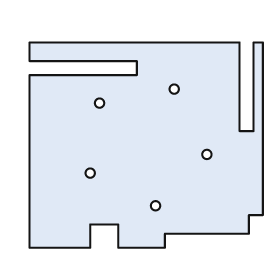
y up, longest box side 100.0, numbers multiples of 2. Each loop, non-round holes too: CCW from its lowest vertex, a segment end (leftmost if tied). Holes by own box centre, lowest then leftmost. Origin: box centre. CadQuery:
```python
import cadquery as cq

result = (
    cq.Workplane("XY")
    .moveTo(-50.0, -44.0)
    .lineTo(-24.0, -44.0)
    .lineTo(-24.0, -34.0)
    .lineTo(-12.0, -34.0)
    .lineTo(-12.0, -44.0)
    .lineTo(8.0, -44.0)
    .lineTo(8.0, -38.0)
    .lineTo(44.0, -38.0)
    .lineTo(44.0, -30.0)
    .lineTo(50.0, -30.0)
    .lineTo(50.0, 44.0)
    .lineTo(46.0, 44.0)
    .lineTo(46.0, 6.0)
    .lineTo(40.0, 6.0)
    .lineTo(40.0, 44.0)
    .lineTo(-50.0, 44.0)
    .lineTo(-50.0, 36.0)
    .lineTo(-4.0, 36.0)
    .lineTo(-4.0, 30.0)
    .lineTo(-50.0, 30.0)
    .close()
    .moveTo(4.0, -26.0)
    .circle(2.0)
    .moveTo(-24.0, -12.0)
    .circle(2.0)
    .moveTo(26.0, -4.0)
    .circle(2.0)
    .moveTo(-20.0, 18.0)
    .circle(2.0)
    .moveTo(12.0, 24.0)
    .circle(2.0)
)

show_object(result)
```